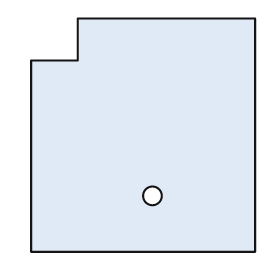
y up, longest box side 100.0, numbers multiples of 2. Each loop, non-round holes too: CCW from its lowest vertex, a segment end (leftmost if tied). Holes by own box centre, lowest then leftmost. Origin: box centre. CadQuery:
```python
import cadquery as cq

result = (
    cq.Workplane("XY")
    .moveTo(-48.0, -50.0)
    .lineTo(48.0, -50.0)
    .lineTo(48.0, 50.0)
    .lineTo(-28.0, 50.0)
    .lineTo(-28.0, 32.0)
    .lineTo(-48.0, 32.0)
    .close()
    .moveTo(4.0, -26.0)
    .circle(4.0)
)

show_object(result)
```